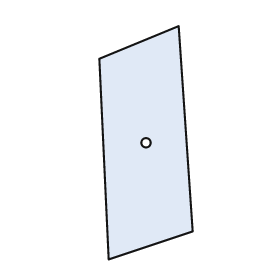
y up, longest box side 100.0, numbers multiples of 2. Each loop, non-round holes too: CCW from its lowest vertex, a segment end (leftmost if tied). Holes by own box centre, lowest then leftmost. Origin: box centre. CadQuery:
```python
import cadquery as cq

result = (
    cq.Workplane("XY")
    .moveTo(-16.0, -50.0)
    .lineTo(20.0, -38.0)
    .lineTo(14.0, 50.0)
    .lineTo(-20.0, 36.0)
    .close()
    .moveTo(0.0, 0.0)
    .circle(2.0)
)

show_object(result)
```